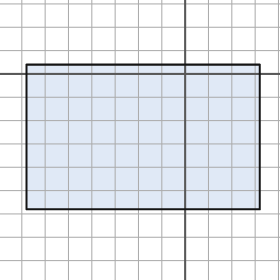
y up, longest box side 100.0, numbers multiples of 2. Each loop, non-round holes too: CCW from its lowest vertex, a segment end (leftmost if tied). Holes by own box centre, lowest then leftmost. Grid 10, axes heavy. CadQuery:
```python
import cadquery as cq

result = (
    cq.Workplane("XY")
    .moveTo(-68.0, -58.0)
    .lineTo(32.0, -58.0)
    .lineTo(32.0, 4.0)
    .lineTo(-68.0, 4.0)
    .close()
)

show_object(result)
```